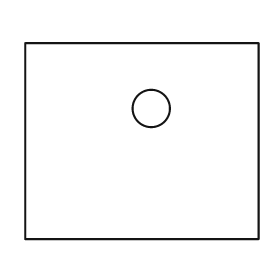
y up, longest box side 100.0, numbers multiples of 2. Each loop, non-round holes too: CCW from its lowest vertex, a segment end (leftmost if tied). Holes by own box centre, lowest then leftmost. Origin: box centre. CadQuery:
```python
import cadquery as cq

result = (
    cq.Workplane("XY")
    .moveTo(-50.0, -42.0)
    .lineTo(50.0, -42.0)
    .lineTo(50.0, 42.0)
    .lineTo(-50.0, 42.0)
    .close()
    .moveTo(4.0, 14.0)
    .circle(8.0)
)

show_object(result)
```